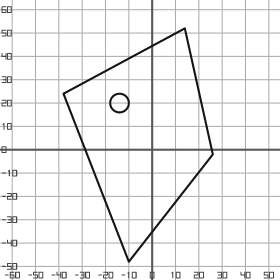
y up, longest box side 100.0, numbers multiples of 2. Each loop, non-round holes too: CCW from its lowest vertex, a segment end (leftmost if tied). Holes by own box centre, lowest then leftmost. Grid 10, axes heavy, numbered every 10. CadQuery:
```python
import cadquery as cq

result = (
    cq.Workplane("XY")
    .moveTo(-10.0, -48.0)
    .lineTo(26.0, -2.0)
    .lineTo(14.0, 52.0)
    .lineTo(-38.0, 24.0)
    .close()
    .moveTo(-14.0, 20.0)
    .circle(4.0)
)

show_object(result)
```